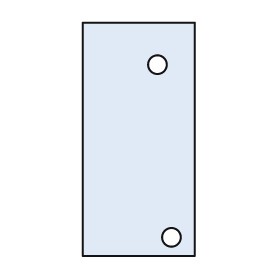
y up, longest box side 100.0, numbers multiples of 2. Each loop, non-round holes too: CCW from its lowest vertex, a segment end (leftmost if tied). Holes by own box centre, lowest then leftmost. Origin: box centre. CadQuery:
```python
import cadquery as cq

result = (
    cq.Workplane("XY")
    .moveTo(-24.0, -50.0)
    .lineTo(24.0, -50.0)
    .lineTo(24.0, 50.0)
    .lineTo(-24.0, 50.0)
    .close()
    .moveTo(14.0, -42.0)
    .circle(4.0)
    .moveTo(8.0, 32.0)
    .circle(4.0)
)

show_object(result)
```